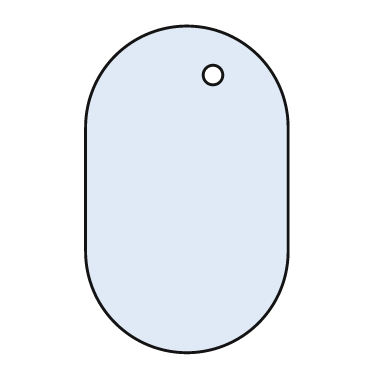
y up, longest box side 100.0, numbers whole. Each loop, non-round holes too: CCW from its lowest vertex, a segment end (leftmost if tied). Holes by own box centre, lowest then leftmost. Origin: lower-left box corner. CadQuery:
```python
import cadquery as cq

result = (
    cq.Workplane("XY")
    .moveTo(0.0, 31.0)
    .threePointArc((31.0, 0.0), (62.0, 31.0))
    .lineTo(62.0, 69.0)
    .threePointArc((31.0, 100.0), (0.0, 69.0))
    .close()
    .moveTo(39.0, 85.0)
    .circle(3.0)
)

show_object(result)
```